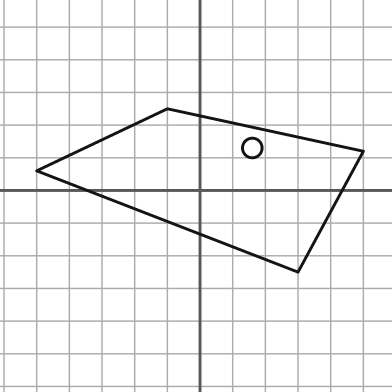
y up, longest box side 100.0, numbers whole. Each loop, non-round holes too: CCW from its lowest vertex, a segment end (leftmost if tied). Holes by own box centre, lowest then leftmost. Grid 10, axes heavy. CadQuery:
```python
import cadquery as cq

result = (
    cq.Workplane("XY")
    .moveTo(30.0, -25.0)
    .lineTo(50.0, 12.0)
    .lineTo(-10.0, 25.0)
    .lineTo(-50.0, 6.0)
    .close()
    .moveTo(16.0, 13.0)
    .circle(3.0)
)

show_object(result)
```